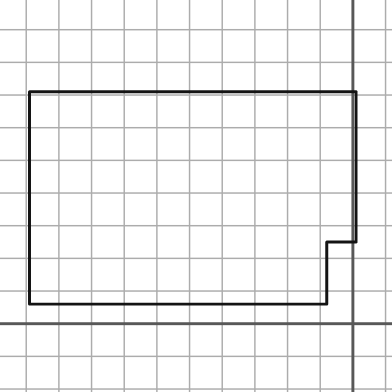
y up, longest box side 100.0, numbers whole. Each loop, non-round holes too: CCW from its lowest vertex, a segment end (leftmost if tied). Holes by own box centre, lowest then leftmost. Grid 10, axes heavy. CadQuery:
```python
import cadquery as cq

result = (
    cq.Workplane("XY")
    .moveTo(-99.0, 6.0)
    .lineTo(-8.0, 6.0)
    .lineTo(-8.0, 25.0)
    .lineTo(1.0, 25.0)
    .lineTo(1.0, 71.0)
    .lineTo(-99.0, 71.0)
    .close()
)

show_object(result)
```